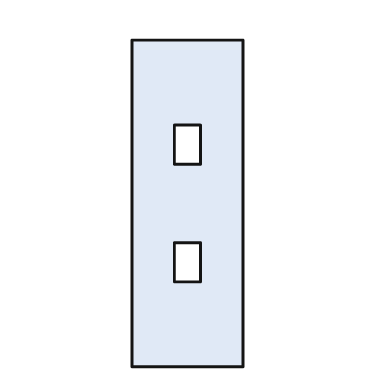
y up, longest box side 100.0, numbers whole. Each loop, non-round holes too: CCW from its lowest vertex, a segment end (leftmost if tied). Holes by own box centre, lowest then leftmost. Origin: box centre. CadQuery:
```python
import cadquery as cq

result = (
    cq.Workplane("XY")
    .moveTo(-17.0, -50.0)
    .lineTo(17.0, -50.0)
    .lineTo(17.0, 50.0)
    .lineTo(-17.0, 50.0)
    .close()
    .moveTo(-4.0, -24.0)
    .lineTo(4.0, -24.0)
    .lineTo(4.0, -12.0)
    .lineTo(-4.0, -12.0)
    .close()
    .moveTo(-4.0, 12.0)
    .lineTo(4.0, 12.0)
    .lineTo(4.0, 24.0)
    .lineTo(-4.0, 24.0)
    .close()
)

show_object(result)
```